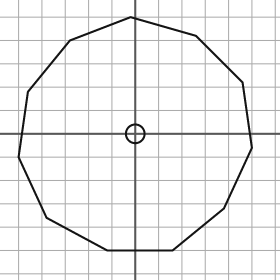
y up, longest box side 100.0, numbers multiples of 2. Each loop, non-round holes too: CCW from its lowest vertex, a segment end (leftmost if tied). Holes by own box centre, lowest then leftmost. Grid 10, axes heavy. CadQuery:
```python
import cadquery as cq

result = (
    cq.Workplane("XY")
    .moveTo(-12.0, -50.0)
    .lineTo(16.0, -50.0)
    .lineTo(38.0, -32.0)
    .lineTo(50.0, -6.0)
    .lineTo(46.0, 22.0)
    .lineTo(26.0, 42.0)
    .lineTo(-2.0, 50.0)
    .lineTo(-28.0, 40.0)
    .lineTo(-46.0, 18.0)
    .lineTo(-50.0, -10.0)
    .lineTo(-38.0, -36.0)
    .close()
    .moveTo(0.0, 0.0)
    .circle(4.0)
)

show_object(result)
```